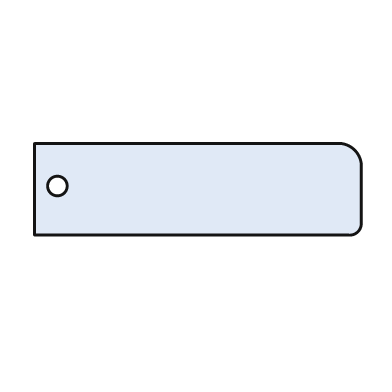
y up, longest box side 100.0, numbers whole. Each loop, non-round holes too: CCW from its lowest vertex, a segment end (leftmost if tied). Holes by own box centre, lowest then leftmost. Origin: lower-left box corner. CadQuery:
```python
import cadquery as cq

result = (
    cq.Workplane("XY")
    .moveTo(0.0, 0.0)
    .lineTo(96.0, 0.0)
    .threePointArc((99.0, 1.0), (100.0, 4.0))
    .lineTo(100.0, 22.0)
    .threePointArc((98.0, 26.0), (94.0, 28.0))
    .lineTo(0.0, 28.0)
    .close()
    .moveTo(7.0, 15.0)
    .circle(3.0)
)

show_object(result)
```